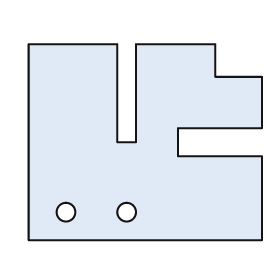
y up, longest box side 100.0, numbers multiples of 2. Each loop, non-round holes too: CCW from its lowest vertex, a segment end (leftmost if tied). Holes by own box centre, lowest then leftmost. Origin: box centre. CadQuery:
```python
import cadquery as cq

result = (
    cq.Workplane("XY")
    .moveTo(-50.0, -42.0)
    .lineTo(50.0, -42.0)
    .lineTo(50.0, -6.0)
    .lineTo(14.0, -6.0)
    .lineTo(14.0, 6.0)
    .lineTo(50.0, 6.0)
    .lineTo(50.0, 28.0)
    .lineTo(30.0, 28.0)
    .lineTo(30.0, 42.0)
    .lineTo(-4.0, 42.0)
    .lineTo(-4.0, 0.0)
    .lineTo(-12.0, 0.0)
    .lineTo(-12.0, 42.0)
    .lineTo(-50.0, 42.0)
    .close()
    .moveTo(-34.0, -30.0)
    .circle(4.0)
    .moveTo(-8.0, -30.0)
    .circle(4.0)
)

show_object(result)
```